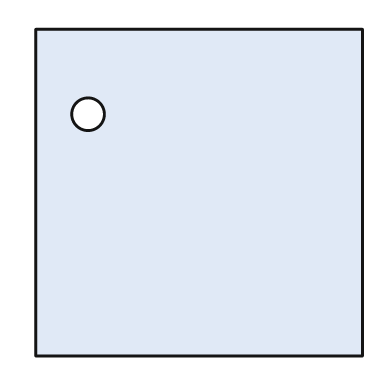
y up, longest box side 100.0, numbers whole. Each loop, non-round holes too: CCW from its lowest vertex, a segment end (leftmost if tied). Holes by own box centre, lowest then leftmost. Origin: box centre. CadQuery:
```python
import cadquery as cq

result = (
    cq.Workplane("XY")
    .moveTo(-50.0, -50.0)
    .lineTo(50.0, -50.0)
    .lineTo(50.0, 50.0)
    .lineTo(-50.0, 50.0)
    .close()
    .moveTo(-34.0, 24.0)
    .circle(5.0)
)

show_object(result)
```